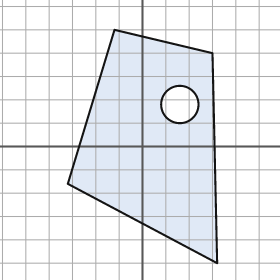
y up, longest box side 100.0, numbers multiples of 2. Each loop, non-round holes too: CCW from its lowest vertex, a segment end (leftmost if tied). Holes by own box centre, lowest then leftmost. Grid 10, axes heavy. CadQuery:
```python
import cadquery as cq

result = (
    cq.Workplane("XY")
    .moveTo(32.0, -50.0)
    .lineTo(30.0, 40.0)
    .lineTo(-12.0, 50.0)
    .lineTo(-32.0, -16.0)
    .close()
    .moveTo(16.0, 18.0)
    .circle(8.0)
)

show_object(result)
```